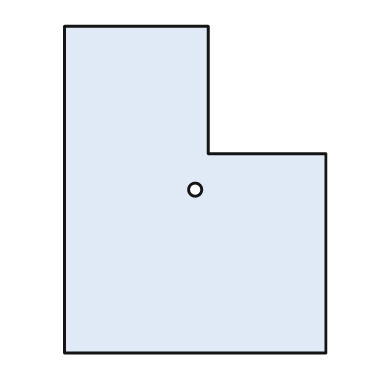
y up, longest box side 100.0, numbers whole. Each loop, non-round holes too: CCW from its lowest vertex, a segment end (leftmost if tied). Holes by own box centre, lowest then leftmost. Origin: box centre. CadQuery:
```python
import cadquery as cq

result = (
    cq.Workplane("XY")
    .moveTo(-40.0, -50.0)
    .lineTo(40.0, -50.0)
    .lineTo(40.0, 11.0)
    .lineTo(4.0, 11.0)
    .lineTo(4.0, 50.0)
    .lineTo(-40.0, 50.0)
    .close()
    .moveTo(0.0, 0.0)
    .circle(2.0)
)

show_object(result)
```